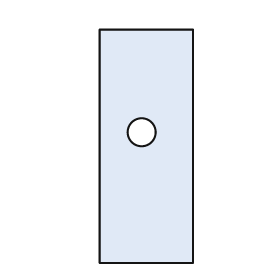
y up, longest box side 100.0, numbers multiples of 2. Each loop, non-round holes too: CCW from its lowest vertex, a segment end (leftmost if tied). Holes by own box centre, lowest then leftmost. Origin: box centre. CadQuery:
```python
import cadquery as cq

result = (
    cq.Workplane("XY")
    .moveTo(-20.0, -50.0)
    .lineTo(20.0, -50.0)
    .lineTo(20.0, 50.0)
    .lineTo(-20.0, 50.0)
    .close()
    .moveTo(-2.0, 6.0)
    .circle(6.0)
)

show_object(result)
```